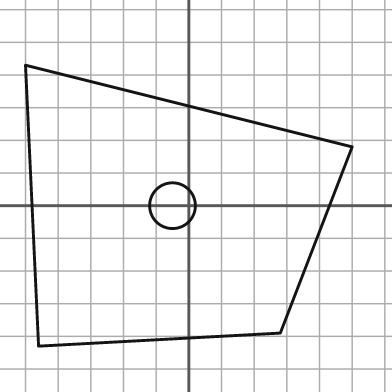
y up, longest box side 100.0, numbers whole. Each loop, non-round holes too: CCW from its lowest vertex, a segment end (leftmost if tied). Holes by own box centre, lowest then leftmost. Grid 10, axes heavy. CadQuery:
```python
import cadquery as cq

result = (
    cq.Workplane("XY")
    .moveTo(-46.0, -43.0)
    .lineTo(28.0, -39.0)
    .lineTo(50.0, 18.0)
    .lineTo(-50.0, 43.0)
    .close()
    .moveTo(-5.0, 0.0)
    .circle(7.0)
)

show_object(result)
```